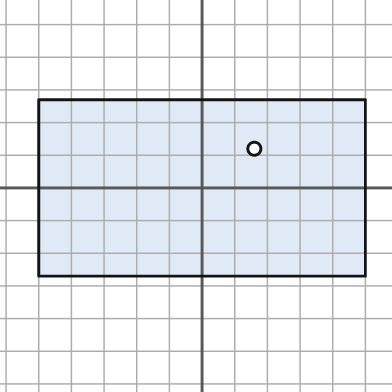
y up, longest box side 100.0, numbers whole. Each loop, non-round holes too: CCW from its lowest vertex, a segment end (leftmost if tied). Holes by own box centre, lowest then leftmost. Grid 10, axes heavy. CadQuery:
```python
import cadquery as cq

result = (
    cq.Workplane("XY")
    .moveTo(-50.0, -27.0)
    .lineTo(50.0, -27.0)
    .lineTo(50.0, 27.0)
    .lineTo(-50.0, 27.0)
    .close()
    .moveTo(16.0, 12.0)
    .circle(2.0)
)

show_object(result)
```